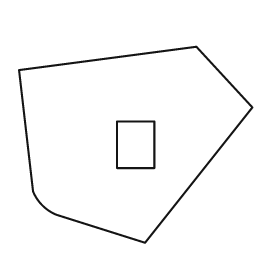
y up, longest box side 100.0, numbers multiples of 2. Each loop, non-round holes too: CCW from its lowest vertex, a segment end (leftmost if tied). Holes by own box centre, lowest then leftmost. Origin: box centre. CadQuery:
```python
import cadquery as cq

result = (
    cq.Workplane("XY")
    .moveTo(4.0, -42.0)
    .lineTo(50.0, 16.0)
    .lineTo(26.0, 42.0)
    .lineTo(-50.0, 32.0)
    .lineTo(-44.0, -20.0)
    .threePointArc((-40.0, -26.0), (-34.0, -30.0))
    .close()
    .moveTo(-8.0, -10.0)
    .lineTo(8.0, -10.0)
    .lineTo(8.0, 10.0)
    .lineTo(-8.0, 10.0)
    .close()
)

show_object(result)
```